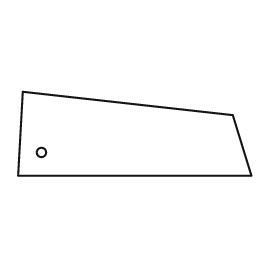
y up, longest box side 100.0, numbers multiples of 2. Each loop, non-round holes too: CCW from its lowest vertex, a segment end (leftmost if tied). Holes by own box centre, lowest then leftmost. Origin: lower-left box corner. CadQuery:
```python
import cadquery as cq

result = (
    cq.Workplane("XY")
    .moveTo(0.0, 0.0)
    .lineTo(100.0, 0.0)
    .lineTo(92.0, 26.0)
    .lineTo(2.0, 36.0)
    .close()
    .moveTo(10.0, 10.0)
    .circle(2.0)
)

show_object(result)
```